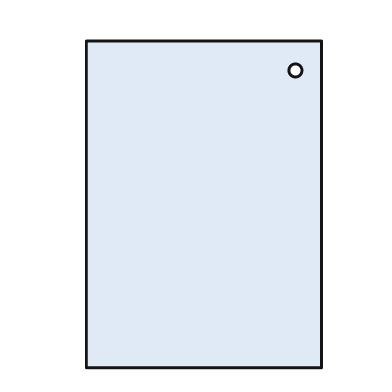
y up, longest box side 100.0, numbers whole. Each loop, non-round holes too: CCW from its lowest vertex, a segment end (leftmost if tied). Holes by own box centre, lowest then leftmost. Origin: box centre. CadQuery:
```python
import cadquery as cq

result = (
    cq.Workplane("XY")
    .moveTo(-36.0, -50.0)
    .lineTo(36.0, -50.0)
    .lineTo(36.0, 50.0)
    .lineTo(-36.0, 50.0)
    .close()
    .moveTo(28.0, 41.0)
    .circle(2.0)
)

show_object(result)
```